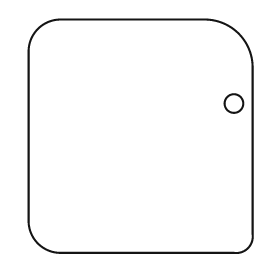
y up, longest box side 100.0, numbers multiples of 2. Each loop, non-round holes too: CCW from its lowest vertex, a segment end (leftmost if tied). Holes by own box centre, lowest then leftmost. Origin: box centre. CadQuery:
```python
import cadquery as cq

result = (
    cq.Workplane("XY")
    .moveTo(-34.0, -50.0)
    .lineTo(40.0, -50.0)
    .threePointArc((46.0, -48.0), (48.0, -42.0))
    .lineTo(48.0, 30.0)
    .threePointArc((42.0, 44.0), (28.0, 50.0))
    .lineTo(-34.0, 50.0)
    .threePointArc((-44.0, 46.0), (-48.0, 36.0))
    .lineTo(-48.0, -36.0)
    .threePointArc((-44.0, -46.0), (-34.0, -50.0))
    .close()
    .moveTo(40.0, 14.0)
    .circle(4.0)
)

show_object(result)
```